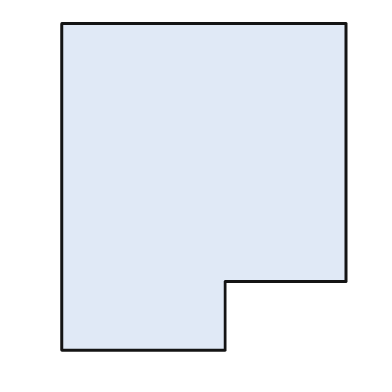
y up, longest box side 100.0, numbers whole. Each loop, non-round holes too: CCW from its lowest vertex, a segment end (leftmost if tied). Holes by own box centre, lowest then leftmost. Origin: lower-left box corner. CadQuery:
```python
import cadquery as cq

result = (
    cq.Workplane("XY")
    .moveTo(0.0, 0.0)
    .lineTo(50.0, 0.0)
    .lineTo(50.0, 21.0)
    .lineTo(87.0, 21.0)
    .lineTo(87.0, 100.0)
    .lineTo(0.0, 100.0)
    .close()
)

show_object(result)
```